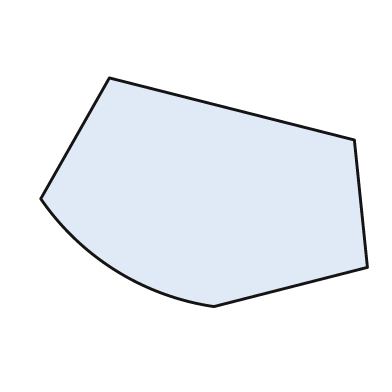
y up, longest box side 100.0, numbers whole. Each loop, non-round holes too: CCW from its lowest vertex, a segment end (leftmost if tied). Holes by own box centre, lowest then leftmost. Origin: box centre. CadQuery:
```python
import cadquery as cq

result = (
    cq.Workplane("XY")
    .moveTo(3.0, -35.0)
    .lineTo(50.0, -23.0)
    .lineTo(46.0, 16.0)
    .lineTo(-29.0, 35.0)
    .lineTo(-50.0, -2.0)
    .threePointArc((-27.0, -24.0), (3.0, -35.0))
    .close()
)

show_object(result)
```